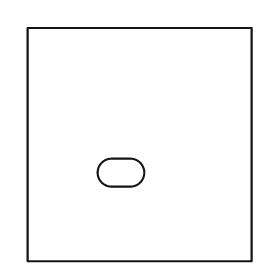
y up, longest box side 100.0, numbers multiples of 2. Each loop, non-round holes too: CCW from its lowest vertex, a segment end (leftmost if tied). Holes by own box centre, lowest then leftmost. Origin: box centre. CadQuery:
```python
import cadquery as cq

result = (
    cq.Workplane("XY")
    .moveTo(-48.0, -50.0)
    .lineTo(48.0, -50.0)
    .lineTo(48.0, 50.0)
    .lineTo(-48.0, 50.0)
    .close()
    .moveTo(-12.0, -18.0)
    .lineTo(-4.0, -18.0)
    .threePointArc((2.0, -12.0), (-4.0, -6.0))
    .lineTo(-12.0, -6.0)
    .threePointArc((-18.0, -12.0), (-12.0, -18.0))
    .close()
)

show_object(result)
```